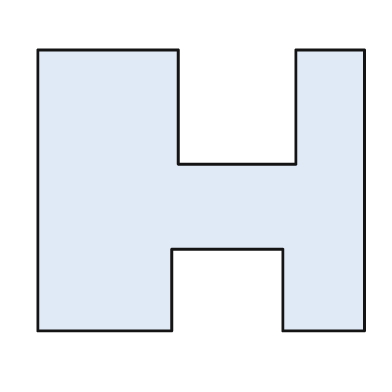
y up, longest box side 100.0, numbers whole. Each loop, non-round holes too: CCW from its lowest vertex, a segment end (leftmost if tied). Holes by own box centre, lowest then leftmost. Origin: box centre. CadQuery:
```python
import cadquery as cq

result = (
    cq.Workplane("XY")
    .moveTo(-50.0, -43.0)
    .lineTo(-9.0, -43.0)
    .lineTo(-9.0, -18.0)
    .lineTo(25.0, -18.0)
    .lineTo(25.0, -43.0)
    .lineTo(50.0, -43.0)
    .lineTo(50.0, 43.0)
    .lineTo(29.0, 43.0)
    .lineTo(29.0, 8.0)
    .lineTo(-7.0, 8.0)
    .lineTo(-7.0, 43.0)
    .lineTo(-50.0, 43.0)
    .close()
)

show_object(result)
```